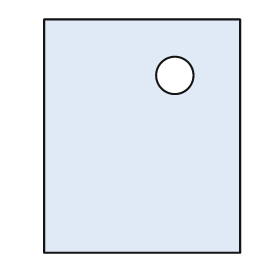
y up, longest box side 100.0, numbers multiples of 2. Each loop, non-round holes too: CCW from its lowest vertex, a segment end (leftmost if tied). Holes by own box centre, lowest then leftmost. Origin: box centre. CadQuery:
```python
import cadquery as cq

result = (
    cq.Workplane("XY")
    .moveTo(-42.0, -50.0)
    .lineTo(42.0, -50.0)
    .lineTo(42.0, 50.0)
    .lineTo(-42.0, 50.0)
    .close()
    .moveTo(14.0, 26.0)
    .circle(8.0)
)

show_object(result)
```